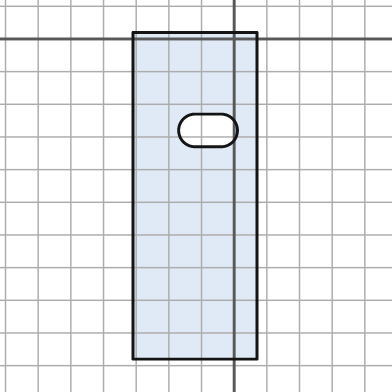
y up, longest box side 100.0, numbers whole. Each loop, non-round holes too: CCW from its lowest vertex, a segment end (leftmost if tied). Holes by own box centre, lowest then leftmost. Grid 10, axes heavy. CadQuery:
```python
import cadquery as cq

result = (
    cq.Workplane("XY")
    .moveTo(-31.0, -98.0)
    .lineTo(7.0, -98.0)
    .lineTo(7.0, 2.0)
    .lineTo(-31.0, 2.0)
    .close()
    .moveTo(-12.0, -33.0)
    .lineTo(-4.0, -33.0)
    .threePointArc((1.0, -28.0), (-4.0, -23.0))
    .lineTo(-12.0, -23.0)
    .threePointArc((-17.0, -28.0), (-12.0, -33.0))
    .close()
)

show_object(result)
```